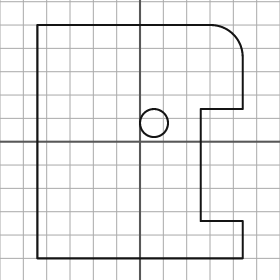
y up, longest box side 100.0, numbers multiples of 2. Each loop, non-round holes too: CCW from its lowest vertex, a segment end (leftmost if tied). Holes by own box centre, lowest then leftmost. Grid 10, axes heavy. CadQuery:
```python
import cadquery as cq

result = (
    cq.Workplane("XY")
    .moveTo(-44.0, -50.0)
    .lineTo(44.0, -50.0)
    .lineTo(44.0, -34.0)
    .lineTo(26.0, -34.0)
    .lineTo(26.0, 14.0)
    .lineTo(44.0, 14.0)
    .lineTo(44.0, 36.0)
    .threePointArc((40.0, 46.0), (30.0, 50.0))
    .lineTo(-44.0, 50.0)
    .close()
    .moveTo(6.0, 8.0)
    .circle(6.0)
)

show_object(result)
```